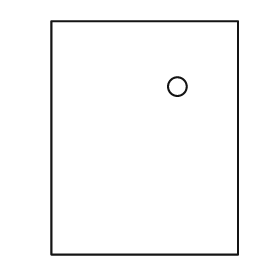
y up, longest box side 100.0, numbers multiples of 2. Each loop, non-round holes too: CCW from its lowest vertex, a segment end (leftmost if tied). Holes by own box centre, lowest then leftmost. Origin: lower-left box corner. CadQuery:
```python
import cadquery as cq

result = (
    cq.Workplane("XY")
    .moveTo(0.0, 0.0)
    .lineTo(80.0, 0.0)
    .lineTo(80.0, 100.0)
    .lineTo(0.0, 100.0)
    .close()
    .moveTo(54.0, 72.0)
    .circle(4.0)
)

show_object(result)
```